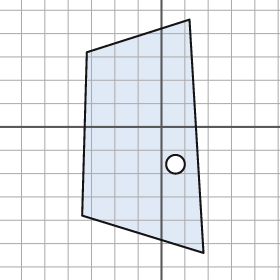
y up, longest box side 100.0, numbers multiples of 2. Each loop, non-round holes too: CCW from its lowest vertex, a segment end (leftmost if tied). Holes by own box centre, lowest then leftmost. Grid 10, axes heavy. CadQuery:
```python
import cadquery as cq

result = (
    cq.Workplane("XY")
    .moveTo(18.0, -54.0)
    .lineTo(12.0, 46.0)
    .lineTo(-32.0, 32.0)
    .lineTo(-34.0, -38.0)
    .close()
    .moveTo(6.0, -16.0)
    .circle(4.0)
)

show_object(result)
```